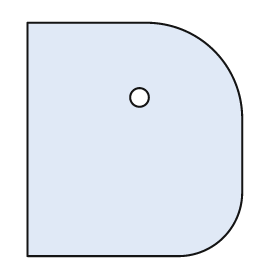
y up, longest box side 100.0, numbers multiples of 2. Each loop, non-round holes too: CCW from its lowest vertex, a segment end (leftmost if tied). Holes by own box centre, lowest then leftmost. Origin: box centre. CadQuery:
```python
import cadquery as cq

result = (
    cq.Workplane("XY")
    .moveTo(-46.0, -50.0)
    .lineTo(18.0, -50.0)
    .threePointArc((38.0, -42.0), (46.0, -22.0))
    .lineTo(46.0, 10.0)
    .threePointArc((34.0, 38.0), (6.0, 50.0))
    .lineTo(-46.0, 50.0)
    .close()
    .moveTo(2.0, 18.0)
    .circle(4.0)
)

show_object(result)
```